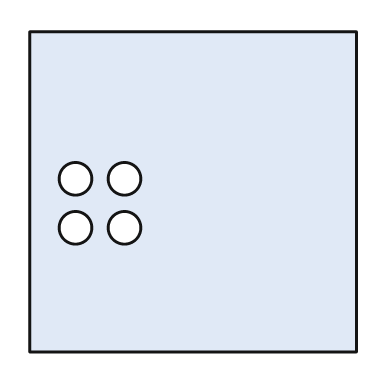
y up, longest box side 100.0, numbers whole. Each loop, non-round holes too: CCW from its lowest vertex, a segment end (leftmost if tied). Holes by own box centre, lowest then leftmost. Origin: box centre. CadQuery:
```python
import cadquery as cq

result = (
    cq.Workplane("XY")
    .moveTo(-50.0, -49.0)
    .lineTo(50.0, -49.0)
    .lineTo(50.0, 49.0)
    .lineTo(-50.0, 49.0)
    .close()
    .moveTo(-36.0, -11.0)
    .circle(5.0)
    .moveTo(-21.0, -11.0)
    .circle(5.0)
    .moveTo(-36.0, 4.0)
    .circle(5.0)
    .moveTo(-21.0, 4.0)
    .circle(5.0)
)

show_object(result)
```